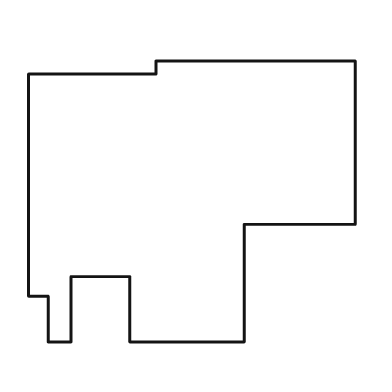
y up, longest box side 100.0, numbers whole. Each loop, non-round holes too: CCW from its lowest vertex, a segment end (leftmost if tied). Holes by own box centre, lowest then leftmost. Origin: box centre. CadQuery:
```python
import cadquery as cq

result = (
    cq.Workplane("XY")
    .moveTo(-44.0, -43.0)
    .lineTo(-37.0, -43.0)
    .lineTo(-37.0, -23.0)
    .lineTo(-19.0, -23.0)
    .lineTo(-19.0, -43.0)
    .lineTo(16.0, -43.0)
    .lineTo(16.0, -7.0)
    .lineTo(50.0, -7.0)
    .lineTo(50.0, 43.0)
    .lineTo(-11.0, 43.0)
    .lineTo(-11.0, 39.0)
    .lineTo(-50.0, 39.0)
    .lineTo(-50.0, -29.0)
    .lineTo(-44.0, -29.0)
    .close()
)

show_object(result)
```